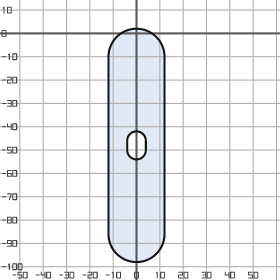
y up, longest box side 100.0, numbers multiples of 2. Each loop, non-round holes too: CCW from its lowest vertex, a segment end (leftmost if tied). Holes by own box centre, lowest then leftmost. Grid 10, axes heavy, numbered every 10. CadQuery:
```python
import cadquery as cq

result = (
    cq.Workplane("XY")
    .moveTo(-12.0, -86.0)
    .threePointArc((0.0, -98.0), (12.0, -86.0))
    .lineTo(12.0, -10.0)
    .threePointArc((0.0, 2.0), (-12.0, -10.0))
    .close()
    .moveTo(-4.0, -50.0)
    .threePointArc((0.0, -54.0), (4.0, -50.0))
    .lineTo(4.0, -46.0)
    .threePointArc((0.0, -42.0), (-4.0, -46.0))
    .close()
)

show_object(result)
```